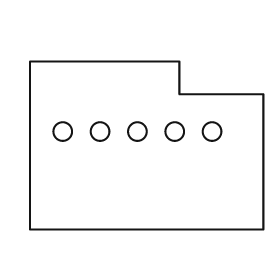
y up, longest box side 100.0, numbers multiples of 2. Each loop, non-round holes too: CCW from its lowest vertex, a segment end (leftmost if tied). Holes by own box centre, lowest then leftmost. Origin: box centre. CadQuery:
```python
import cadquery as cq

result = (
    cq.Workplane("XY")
    .moveTo(-50.0, -36.0)
    .lineTo(50.0, -36.0)
    .lineTo(50.0, 22.0)
    .lineTo(14.0, 22.0)
    .lineTo(14.0, 36.0)
    .lineTo(-50.0, 36.0)
    .close()
    .moveTo(-36.0, 6.0)
    .circle(4.0)
    .moveTo(-20.0, 6.0)
    .circle(4.0)
    .moveTo(-4.0, 6.0)
    .circle(4.0)
    .moveTo(12.0, 6.0)
    .circle(4.0)
    .moveTo(28.0, 6.0)
    .circle(4.0)
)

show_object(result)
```